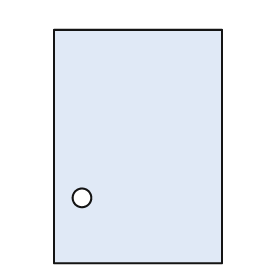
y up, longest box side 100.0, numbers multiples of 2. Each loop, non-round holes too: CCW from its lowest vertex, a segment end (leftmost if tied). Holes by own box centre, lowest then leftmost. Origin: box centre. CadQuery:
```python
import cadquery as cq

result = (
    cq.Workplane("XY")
    .moveTo(-36.0, -50.0)
    .lineTo(36.0, -50.0)
    .lineTo(36.0, 50.0)
    .lineTo(-36.0, 50.0)
    .close()
    .moveTo(-24.0, -22.0)
    .circle(4.0)
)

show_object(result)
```